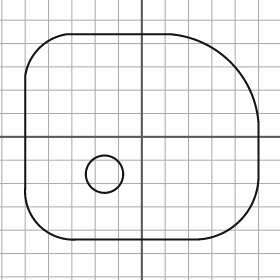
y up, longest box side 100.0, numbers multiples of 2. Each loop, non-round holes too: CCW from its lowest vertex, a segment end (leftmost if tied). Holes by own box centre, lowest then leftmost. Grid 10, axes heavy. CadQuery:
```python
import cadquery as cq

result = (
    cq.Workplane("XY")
    .moveTo(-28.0, -44.0)
    .lineTo(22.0, -44.0)
    .threePointArc((42.0, -36.0), (50.0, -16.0))
    .lineTo(50.0, 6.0)
    .threePointArc((38.0, 32.0), (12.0, 44.0))
    .lineTo(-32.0, 44.0)
    .threePointArc((-44.0, 38.0), (-50.0, 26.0))
    .lineTo(-50.0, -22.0)
    .threePointArc((-44.0, -38.0), (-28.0, -44.0))
    .close()
    .moveTo(-16.0, -16.0)
    .circle(8.0)
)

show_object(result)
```